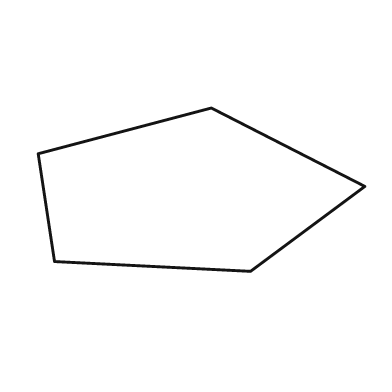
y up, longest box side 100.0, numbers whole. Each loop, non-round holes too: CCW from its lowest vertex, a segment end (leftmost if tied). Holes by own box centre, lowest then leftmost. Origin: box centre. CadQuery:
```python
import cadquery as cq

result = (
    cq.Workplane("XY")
    .moveTo(15.0, -25.0)
    .lineTo(50.0, 1.0)
    .lineTo(3.0, 25.0)
    .lineTo(-50.0, 11.0)
    .lineTo(-45.0, -22.0)
    .close()
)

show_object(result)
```